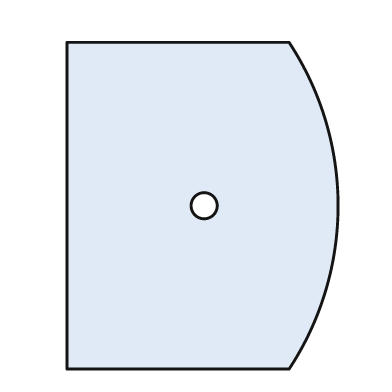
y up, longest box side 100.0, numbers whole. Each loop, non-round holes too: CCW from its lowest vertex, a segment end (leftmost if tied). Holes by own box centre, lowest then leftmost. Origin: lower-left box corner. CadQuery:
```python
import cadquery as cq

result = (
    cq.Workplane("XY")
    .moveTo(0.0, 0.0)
    .lineTo(68.0, 0.0)
    .threePointArc((83.0, 50.0), (68.0, 100.0))
    .lineTo(0.0, 100.0)
    .close()
    .moveTo(42.0, 50.0)
    .circle(4.0)
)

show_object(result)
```